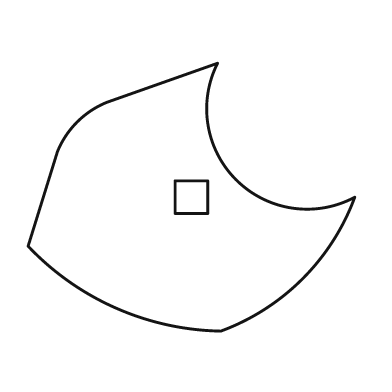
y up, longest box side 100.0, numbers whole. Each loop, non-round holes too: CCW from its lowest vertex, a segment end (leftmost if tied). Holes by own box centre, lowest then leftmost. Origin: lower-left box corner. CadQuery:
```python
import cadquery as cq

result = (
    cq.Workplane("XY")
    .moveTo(59.0, 0.0)
    .threePointArc((84.0, 16.0), (100.0, 41.0))
    .threePointArc((64.0, 46.0), (58.0, 82.0))
    .lineTo(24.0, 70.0)
    .threePointArc((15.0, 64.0), (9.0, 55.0))
    .lineTo(0.0, 26.0)
    .threePointArc((27.0, 7.0), (59.0, 0.0))
    .close()
    .moveTo(45.0, 36.0)
    .lineTo(55.0, 36.0)
    .lineTo(55.0, 46.0)
    .lineTo(45.0, 46.0)
    .close()
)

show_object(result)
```